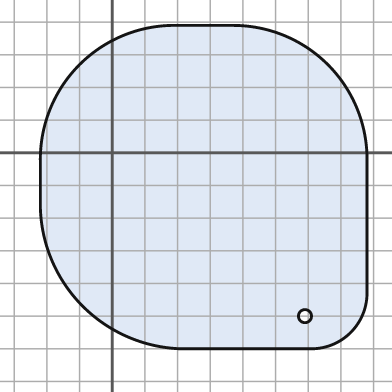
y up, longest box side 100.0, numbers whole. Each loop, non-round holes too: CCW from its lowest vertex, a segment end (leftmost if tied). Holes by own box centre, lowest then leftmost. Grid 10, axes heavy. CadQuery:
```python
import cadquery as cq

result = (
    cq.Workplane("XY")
    .moveTo(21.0, -60.0)
    .lineTo(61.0, -60.0)
    .threePointArc((73.0, -55.0), (78.0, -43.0))
    .lineTo(78.0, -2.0)
    .threePointArc((66.0, 27.0), (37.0, 39.0))
    .lineTo(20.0, 39.0)
    .threePointArc((-10.0, 27.0), (-22.0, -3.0))
    .lineTo(-22.0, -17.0)
    .threePointArc((-9.0, -47.0), (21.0, -60.0))
    .close()
    .moveTo(59.0, -50.0)
    .circle(2.0)
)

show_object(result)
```